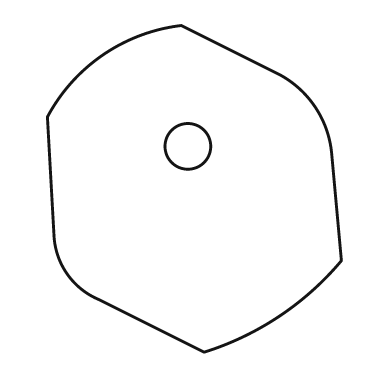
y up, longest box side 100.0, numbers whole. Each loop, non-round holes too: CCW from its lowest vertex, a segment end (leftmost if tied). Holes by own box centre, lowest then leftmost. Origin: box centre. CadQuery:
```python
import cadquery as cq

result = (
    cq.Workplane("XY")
    .moveTo(3.0, -50.0)
    .threePointArc((26.0, -39.0), (45.0, -22.0))
    .lineTo(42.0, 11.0)
    .threePointArc((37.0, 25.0), (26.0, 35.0))
    .lineTo(-4.0, 50.0)
    .threePointArc((-28.0, 41.0), (-45.0, 22.0))
    .lineTo(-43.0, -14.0)
    .threePointArc((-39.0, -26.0), (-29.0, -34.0))
    .close()
    .moveTo(-2.0, 13.0)
    .circle(7.0)
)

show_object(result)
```